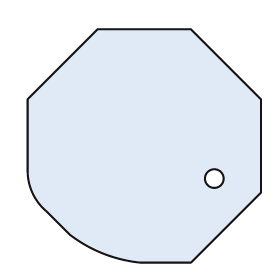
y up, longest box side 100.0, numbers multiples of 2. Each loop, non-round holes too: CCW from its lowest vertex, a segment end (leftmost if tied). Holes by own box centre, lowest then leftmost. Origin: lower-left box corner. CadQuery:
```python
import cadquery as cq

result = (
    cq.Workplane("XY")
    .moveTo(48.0, 0.0)
    .lineTo(70.0, 0.0)
    .lineTo(100.0, 30.0)
    .lineTo(100.0, 70.0)
    .lineTo(70.0, 100.0)
    .lineTo(30.0, 100.0)
    .lineTo(0.0, 70.0)
    .lineTo(0.0, 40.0)
    .threePointArc((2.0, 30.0), (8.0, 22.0))
    .lineTo(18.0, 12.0)
    .threePointArc((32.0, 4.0), (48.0, 0.0))
    .close()
    .moveTo(80.0, 36.0)
    .circle(4.0)
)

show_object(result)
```